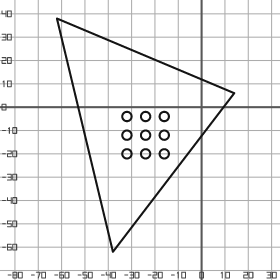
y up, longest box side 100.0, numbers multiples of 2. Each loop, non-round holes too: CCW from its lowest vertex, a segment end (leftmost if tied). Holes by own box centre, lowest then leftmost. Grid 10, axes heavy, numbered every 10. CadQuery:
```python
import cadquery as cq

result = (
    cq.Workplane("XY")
    .moveTo(-38.0, -62.0)
    .lineTo(14.0, 6.0)
    .lineTo(-62.0, 38.0)
    .close()
    .moveTo(-32.0, -20.0)
    .circle(2.0)
    .moveTo(-24.0, -20.0)
    .circle(2.0)
    .moveTo(-16.0, -20.0)
    .circle(2.0)
    .moveTo(-32.0, -12.0)
    .circle(2.0)
    .moveTo(-24.0, -12.0)
    .circle(2.0)
    .moveTo(-16.0, -12.0)
    .circle(2.0)
    .moveTo(-32.0, -4.0)
    .circle(2.0)
    .moveTo(-24.0, -4.0)
    .circle(2.0)
    .moveTo(-16.0, -4.0)
    .circle(2.0)
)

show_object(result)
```